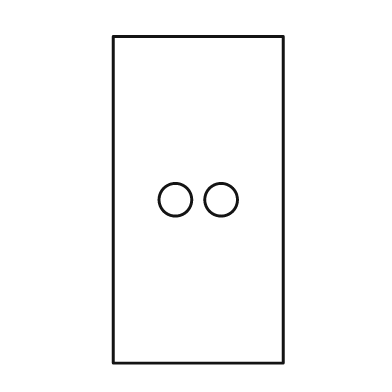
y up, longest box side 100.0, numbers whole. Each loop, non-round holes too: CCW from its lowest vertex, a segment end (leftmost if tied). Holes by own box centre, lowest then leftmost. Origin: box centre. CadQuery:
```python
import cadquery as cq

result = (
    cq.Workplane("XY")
    .moveTo(-26.0, -50.0)
    .lineTo(26.0, -50.0)
    .lineTo(26.0, 50.0)
    .lineTo(-26.0, 50.0)
    .close()
    .moveTo(-7.0, 0.0)
    .circle(5.0)
    .moveTo(7.0, 0.0)
    .circle(5.0)
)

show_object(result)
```